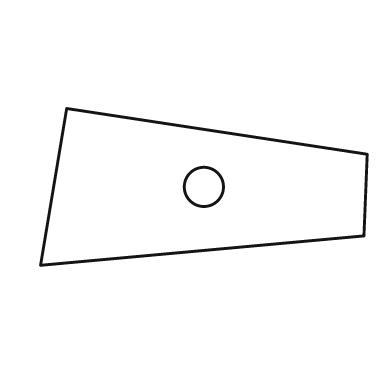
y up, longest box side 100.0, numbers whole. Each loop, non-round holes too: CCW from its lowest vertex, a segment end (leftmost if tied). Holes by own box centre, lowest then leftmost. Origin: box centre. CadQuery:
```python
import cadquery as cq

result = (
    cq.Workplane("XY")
    .moveTo(-50.0, -24.0)
    .lineTo(49.0, -15.0)
    .lineTo(50.0, 10.0)
    .lineTo(-42.0, 24.0)
    .close()
    .moveTo(0.0, 0.0)
    .circle(6.0)
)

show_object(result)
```